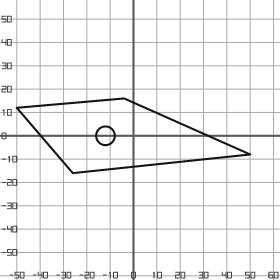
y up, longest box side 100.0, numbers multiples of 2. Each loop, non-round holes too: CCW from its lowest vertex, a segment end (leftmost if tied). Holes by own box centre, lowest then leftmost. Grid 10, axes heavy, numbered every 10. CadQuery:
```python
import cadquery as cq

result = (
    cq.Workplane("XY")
    .moveTo(-26.0, -16.0)
    .lineTo(50.0, -8.0)
    .lineTo(-4.0, 16.0)
    .lineTo(-50.0, 12.0)
    .close()
    .moveTo(-12.0, 0.0)
    .circle(4.0)
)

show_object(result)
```